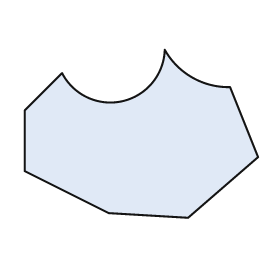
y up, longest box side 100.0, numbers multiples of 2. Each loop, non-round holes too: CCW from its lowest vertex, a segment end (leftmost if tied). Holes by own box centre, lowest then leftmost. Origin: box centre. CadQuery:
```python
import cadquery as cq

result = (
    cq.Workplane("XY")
    .moveTo(20.0, -36.0)
    .lineTo(50.0, -10.0)
    .lineTo(38.0, 20.0)
    .threePointArc((22.0, 24.0), (10.0, 36.0))
    .threePointArc((-8.0, 14.0), (-34.0, 26.0))
    .lineTo(-50.0, 10.0)
    .lineTo(-50.0, -16.0)
    .lineTo(-14.0, -34.0)
    .close()
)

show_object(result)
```